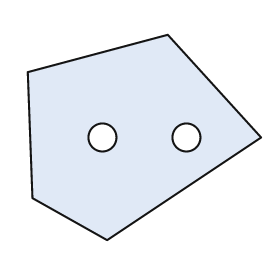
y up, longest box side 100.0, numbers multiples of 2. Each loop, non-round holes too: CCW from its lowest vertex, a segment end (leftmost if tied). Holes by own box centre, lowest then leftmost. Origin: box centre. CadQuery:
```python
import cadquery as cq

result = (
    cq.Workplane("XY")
    .moveTo(-16.0, -44.0)
    .lineTo(50.0, 0.0)
    .lineTo(10.0, 44.0)
    .lineTo(-50.0, 28.0)
    .lineTo(-48.0, -26.0)
    .close()
    .moveTo(-18.0, 0.0)
    .circle(6.0)
    .moveTo(18.0, 0.0)
    .circle(6.0)
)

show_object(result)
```